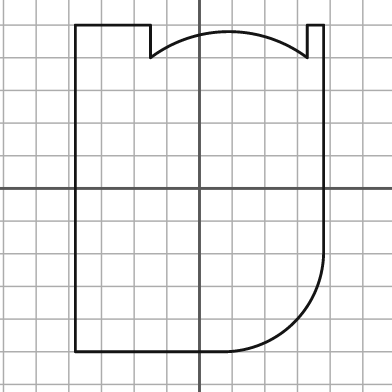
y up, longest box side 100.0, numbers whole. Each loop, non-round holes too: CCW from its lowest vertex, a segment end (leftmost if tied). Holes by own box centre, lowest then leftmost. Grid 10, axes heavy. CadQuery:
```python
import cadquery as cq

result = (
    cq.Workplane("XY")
    .moveTo(-38.0, -50.0)
    .lineTo(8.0, -50.0)
    .threePointArc((29.0, -41.0), (38.0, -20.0))
    .lineTo(38.0, 50.0)
    .lineTo(33.0, 50.0)
    .lineTo(33.0, 40.0)
    .threePointArc((9.0, 48.0), (-15.0, 40.0))
    .lineTo(-15.0, 50.0)
    .lineTo(-38.0, 50.0)
    .close()
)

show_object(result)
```